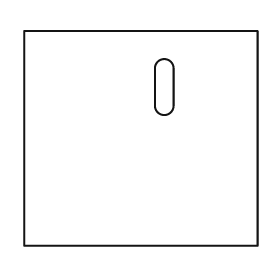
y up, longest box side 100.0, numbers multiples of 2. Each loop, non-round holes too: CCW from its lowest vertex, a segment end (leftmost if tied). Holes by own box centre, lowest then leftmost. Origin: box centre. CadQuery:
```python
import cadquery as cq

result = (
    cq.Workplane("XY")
    .moveTo(-50.0, -46.0)
    .lineTo(50.0, -46.0)
    .lineTo(50.0, 46.0)
    .lineTo(-50.0, 46.0)
    .close()
    .moveTo(6.0, 14.0)
    .threePointArc((10.0, 10.0), (14.0, 14.0))
    .lineTo(14.0, 30.0)
    .threePointArc((10.0, 34.0), (6.0, 30.0))
    .close()
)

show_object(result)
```